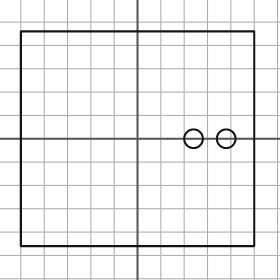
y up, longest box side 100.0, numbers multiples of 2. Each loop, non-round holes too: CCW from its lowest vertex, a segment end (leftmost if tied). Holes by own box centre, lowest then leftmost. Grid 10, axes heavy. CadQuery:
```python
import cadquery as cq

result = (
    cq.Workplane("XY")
    .moveTo(-50.0, -46.0)
    .lineTo(50.0, -46.0)
    .lineTo(50.0, 46.0)
    .lineTo(-50.0, 46.0)
    .close()
    .moveTo(24.0, 0.0)
    .circle(4.0)
    .moveTo(38.0, 0.0)
    .circle(4.0)
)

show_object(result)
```